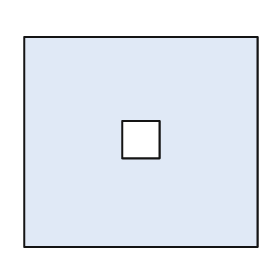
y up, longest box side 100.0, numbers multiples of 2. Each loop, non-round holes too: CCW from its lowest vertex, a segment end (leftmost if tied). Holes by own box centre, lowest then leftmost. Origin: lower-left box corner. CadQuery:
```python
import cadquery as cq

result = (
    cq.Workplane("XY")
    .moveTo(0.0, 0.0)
    .lineTo(100.0, 0.0)
    .lineTo(100.0, 90.0)
    .lineTo(0.0, 90.0)
    .close()
    .moveTo(42.0, 38.0)
    .lineTo(58.0, 38.0)
    .lineTo(58.0, 54.0)
    .lineTo(42.0, 54.0)
    .close()
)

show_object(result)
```